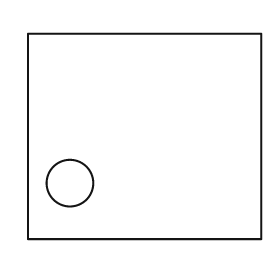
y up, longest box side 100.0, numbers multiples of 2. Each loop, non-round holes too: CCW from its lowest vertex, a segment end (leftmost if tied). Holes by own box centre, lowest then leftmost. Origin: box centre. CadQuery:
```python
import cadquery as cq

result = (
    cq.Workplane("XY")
    .moveTo(-50.0, -44.0)
    .lineTo(50.0, -44.0)
    .lineTo(50.0, 44.0)
    .lineTo(-50.0, 44.0)
    .close()
    .moveTo(-32.0, -20.0)
    .circle(10.0)
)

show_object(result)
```